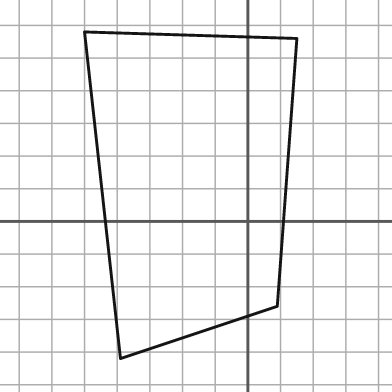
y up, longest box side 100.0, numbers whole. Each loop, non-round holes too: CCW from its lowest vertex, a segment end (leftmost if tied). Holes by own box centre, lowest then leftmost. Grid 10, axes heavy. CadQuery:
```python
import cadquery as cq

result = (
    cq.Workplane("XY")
    .moveTo(-39.0, -42.0)
    .lineTo(9.0, -26.0)
    .lineTo(15.0, 56.0)
    .lineTo(-50.0, 58.0)
    .close()
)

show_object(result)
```